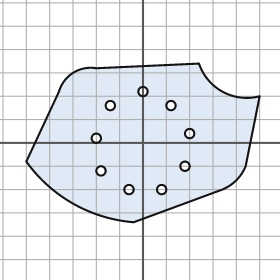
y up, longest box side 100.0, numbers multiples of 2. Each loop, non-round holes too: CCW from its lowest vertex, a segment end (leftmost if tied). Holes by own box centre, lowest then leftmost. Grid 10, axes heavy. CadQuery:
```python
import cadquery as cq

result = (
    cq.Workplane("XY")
    .moveTo(-4.0, -34.0)
    .lineTo(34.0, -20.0)
    .threePointArc((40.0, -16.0), (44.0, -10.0))
    .lineTo(50.0, 20.0)
    .threePointArc((34.0, 22.0), (24.0, 34.0))
    .lineTo(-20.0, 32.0)
    .threePointArc((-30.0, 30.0), (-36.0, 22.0))
    .lineTo(-50.0, -8.0)
    .threePointArc((-30.0, -26.0), (-4.0, -34.0))
    .close()
    .moveTo(-6.0, -20.0)
    .circle(2.0)
    .moveTo(8.0, -20.0)
    .circle(2.0)
    .moveTo(-18.0, -12.0)
    .circle(2.0)
    .moveTo(18.0, -10.0)
    .circle(2.0)
    .moveTo(-20.0, 2.0)
    .circle(2.0)
    .moveTo(20.0, 4.0)
    .circle(2.0)
    .moveTo(-14.0, 16.0)
    .circle(2.0)
    .moveTo(12.0, 16.0)
    .circle(2.0)
    .moveTo(0.0, 22.0)
    .circle(2.0)
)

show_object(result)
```